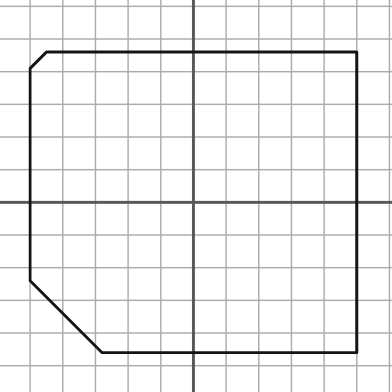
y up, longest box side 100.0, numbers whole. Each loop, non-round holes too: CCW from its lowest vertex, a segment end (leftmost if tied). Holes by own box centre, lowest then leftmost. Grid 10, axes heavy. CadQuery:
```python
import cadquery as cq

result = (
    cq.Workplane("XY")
    .moveTo(-28.0, -46.0)
    .lineTo(50.0, -46.0)
    .lineTo(50.0, 46.0)
    .lineTo(-45.0, 46.0)
    .lineTo(-50.0, 41.0)
    .lineTo(-50.0, -24.0)
    .close()
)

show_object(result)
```